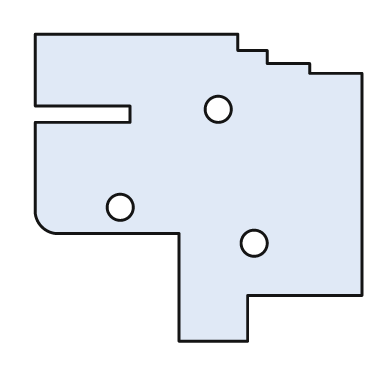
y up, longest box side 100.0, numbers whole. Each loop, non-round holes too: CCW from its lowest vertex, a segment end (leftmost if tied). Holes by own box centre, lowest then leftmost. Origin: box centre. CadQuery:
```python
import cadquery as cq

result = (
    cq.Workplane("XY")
    .moveTo(-6.0, -47.0)
    .lineTo(15.0, -47.0)
    .lineTo(15.0, -33.0)
    .lineTo(50.0, -33.0)
    .lineTo(50.0, 35.0)
    .lineTo(34.0, 35.0)
    .lineTo(34.0, 38.0)
    .lineTo(21.0, 38.0)
    .lineTo(21.0, 42.0)
    .lineTo(12.0, 42.0)
    .lineTo(12.0, 47.0)
    .lineTo(-50.0, 47.0)
    .lineTo(-50.0, 25.0)
    .lineTo(-21.0, 25.0)
    .lineTo(-21.0, 20.0)
    .lineTo(-50.0, 20.0)
    .lineTo(-50.0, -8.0)
    .threePointArc((-48.0, -12.0), (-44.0, -14.0))
    .lineTo(-6.0, -14.0)
    .close()
    .moveTo(17.0, -17.0)
    .circle(4.0)
    .moveTo(-24.0, -6.0)
    .circle(4.0)
    .moveTo(6.0, 24.0)
    .circle(4.0)
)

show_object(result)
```